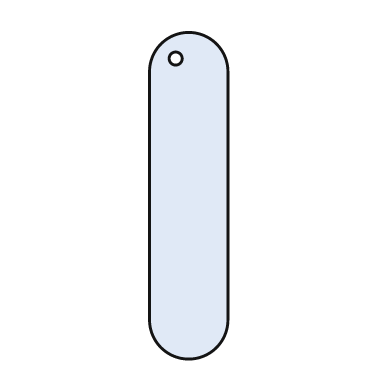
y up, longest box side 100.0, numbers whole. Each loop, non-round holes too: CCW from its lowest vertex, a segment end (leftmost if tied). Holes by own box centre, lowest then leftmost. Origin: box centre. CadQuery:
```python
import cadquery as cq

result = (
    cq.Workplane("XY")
    .moveTo(-12.0, -38.0)
    .threePointArc((0.0, -50.0), (12.0, -38.0))
    .lineTo(12.0, 38.0)
    .threePointArc((0.0, 50.0), (-12.0, 38.0))
    .close()
    .moveTo(-4.0, 42.0)
    .circle(2.0)
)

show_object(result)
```